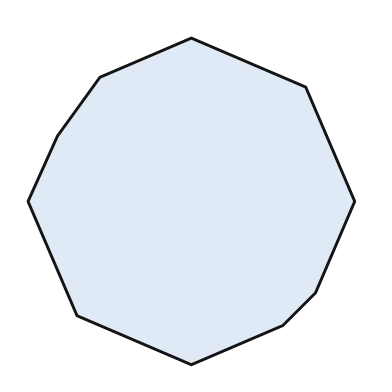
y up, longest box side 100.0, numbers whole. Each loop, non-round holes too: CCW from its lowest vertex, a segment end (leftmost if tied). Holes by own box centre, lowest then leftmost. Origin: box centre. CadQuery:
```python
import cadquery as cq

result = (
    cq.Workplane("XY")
    .moveTo(0.0, -50.0)
    .lineTo(28.0, -38.0)
    .lineTo(38.0, -28.0)
    .lineTo(50.0, 0.0)
    .lineTo(35.0, 35.0)
    .lineTo(0.0, 50.0)
    .lineTo(-28.0, 38.0)
    .lineTo(-41.0, 20.0)
    .lineTo(-50.0, 0.0)
    .lineTo(-35.0, -35.0)
    .close()
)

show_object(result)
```